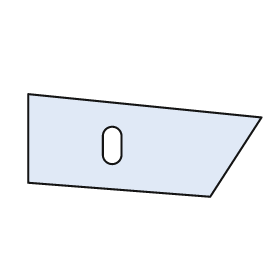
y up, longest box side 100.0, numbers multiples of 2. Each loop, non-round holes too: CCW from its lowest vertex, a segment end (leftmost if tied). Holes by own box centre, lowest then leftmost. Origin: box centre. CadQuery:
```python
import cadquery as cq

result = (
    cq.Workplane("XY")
    .moveTo(28.0, -22.0)
    .lineTo(50.0, 12.0)
    .lineTo(-50.0, 22.0)
    .lineTo(-50.0, -16.0)
    .close()
    .moveTo(-18.0, -4.0)
    .threePointArc((-14.0, -8.0), (-10.0, -4.0))
    .lineTo(-10.0, 4.0)
    .threePointArc((-14.0, 8.0), (-18.0, 4.0))
    .close()
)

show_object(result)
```